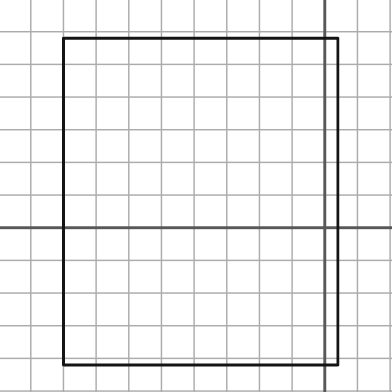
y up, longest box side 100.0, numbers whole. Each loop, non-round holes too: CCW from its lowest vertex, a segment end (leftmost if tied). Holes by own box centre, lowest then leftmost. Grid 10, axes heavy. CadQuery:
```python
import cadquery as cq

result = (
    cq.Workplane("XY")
    .moveTo(-80.0, -42.0)
    .lineTo(4.0, -42.0)
    .lineTo(4.0, 58.0)
    .lineTo(-80.0, 58.0)
    .close()
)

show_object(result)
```